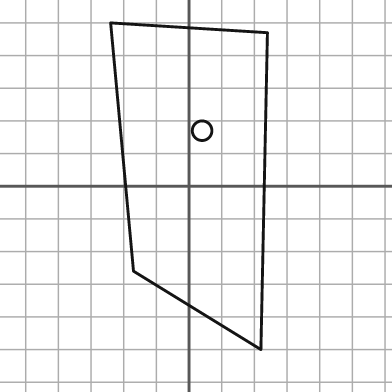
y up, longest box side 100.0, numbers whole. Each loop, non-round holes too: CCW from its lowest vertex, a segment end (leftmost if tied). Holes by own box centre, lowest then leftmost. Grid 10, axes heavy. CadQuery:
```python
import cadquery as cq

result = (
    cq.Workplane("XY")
    .moveTo(22.0, -50.0)
    .lineTo(24.0, 47.0)
    .lineTo(-24.0, 50.0)
    .lineTo(-17.0, -26.0)
    .close()
    .moveTo(4.0, 17.0)
    .circle(3.0)
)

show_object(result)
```